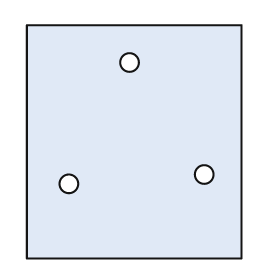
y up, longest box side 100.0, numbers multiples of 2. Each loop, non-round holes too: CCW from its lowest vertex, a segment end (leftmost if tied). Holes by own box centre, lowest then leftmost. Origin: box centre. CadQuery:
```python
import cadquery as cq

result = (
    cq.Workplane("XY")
    .moveTo(-46.0, -50.0)
    .lineTo(46.0, -50.0)
    .lineTo(46.0, 50.0)
    .lineTo(-46.0, 50.0)
    .close()
    .moveTo(-28.0, -18.0)
    .circle(4.0)
    .moveTo(30.0, -14.0)
    .circle(4.0)
    .moveTo(-2.0, 34.0)
    .circle(4.0)
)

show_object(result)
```